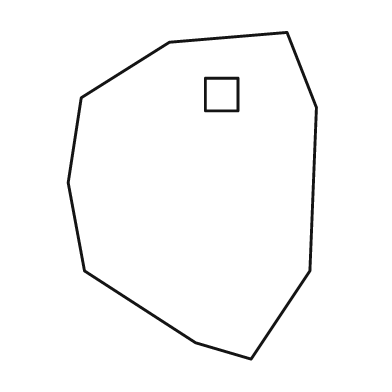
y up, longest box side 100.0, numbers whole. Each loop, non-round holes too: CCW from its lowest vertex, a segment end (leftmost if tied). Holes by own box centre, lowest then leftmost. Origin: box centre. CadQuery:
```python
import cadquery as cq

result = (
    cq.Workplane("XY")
    .moveTo(18.0, -50.0)
    .lineTo(36.0, -23.0)
    .lineTo(38.0, 27.0)
    .lineTo(29.0, 50.0)
    .lineTo(-7.0, 47.0)
    .lineTo(-34.0, 30.0)
    .lineTo(-38.0, 4.0)
    .lineTo(-33.0, -23.0)
    .lineTo(1.0, -45.0)
    .close()
    .moveTo(4.0, 26.0)
    .lineTo(14.0, 26.0)
    .lineTo(14.0, 36.0)
    .lineTo(4.0, 36.0)
    .close()
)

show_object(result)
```